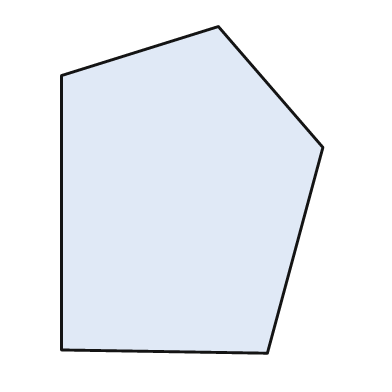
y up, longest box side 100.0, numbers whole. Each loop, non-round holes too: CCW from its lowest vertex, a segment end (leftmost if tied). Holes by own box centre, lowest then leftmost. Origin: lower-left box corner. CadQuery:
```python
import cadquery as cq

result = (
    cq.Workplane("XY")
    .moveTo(63.0, 0.0)
    .lineTo(80.0, 63.0)
    .lineTo(48.0, 100.0)
    .lineTo(0.0, 85.0)
    .lineTo(0.0, 1.0)
    .close()
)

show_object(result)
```